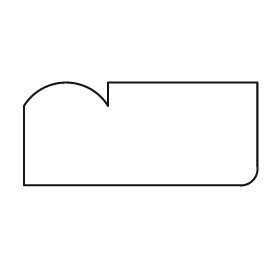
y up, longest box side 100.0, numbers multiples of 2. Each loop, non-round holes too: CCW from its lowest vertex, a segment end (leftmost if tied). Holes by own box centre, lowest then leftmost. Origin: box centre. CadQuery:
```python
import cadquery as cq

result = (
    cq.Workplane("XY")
    .moveTo(-50.0, -22.0)
    .lineTo(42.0, -22.0)
    .threePointArc((48.0, -20.0), (50.0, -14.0))
    .lineTo(50.0, 22.0)
    .lineTo(-14.0, 22.0)
    .lineTo(-14.0, 12.0)
    .threePointArc((-32.0, 22.0), (-50.0, 12.0))
    .close()
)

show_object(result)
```